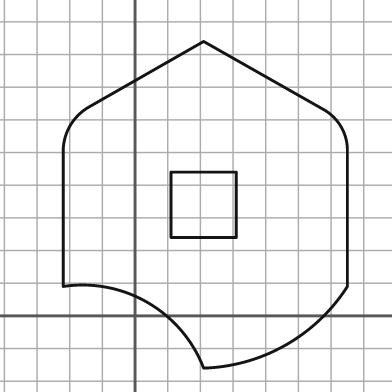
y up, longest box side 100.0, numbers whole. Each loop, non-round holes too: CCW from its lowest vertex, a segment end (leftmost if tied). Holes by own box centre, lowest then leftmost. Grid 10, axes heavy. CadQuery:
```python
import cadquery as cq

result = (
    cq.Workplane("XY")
    .moveTo(21.0, -16.0)
    .threePointArc((46.0, -9.0), (65.0, 9.0))
    .lineTo(65.0, 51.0)
    .threePointArc((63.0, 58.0), (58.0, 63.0))
    .lineTo(21.0, 84.0)
    .lineTo(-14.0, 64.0)
    .threePointArc((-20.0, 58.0), (-22.0, 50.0))
    .lineTo(-22.0, 9.0)
    .threePointArc((4.0, 4.0), (21.0, -16.0))
    .close()
    .moveTo(11.0, 24.0)
    .lineTo(31.0, 24.0)
    .lineTo(31.0, 44.0)
    .lineTo(11.0, 44.0)
    .close()
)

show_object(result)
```